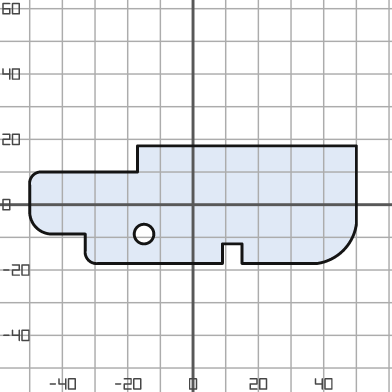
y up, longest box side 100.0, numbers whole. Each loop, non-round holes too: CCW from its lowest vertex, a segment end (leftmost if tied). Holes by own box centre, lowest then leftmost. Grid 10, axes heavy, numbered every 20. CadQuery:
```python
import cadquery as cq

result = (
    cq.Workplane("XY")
    .moveTo(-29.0, -18.0)
    .lineTo(9.0, -18.0)
    .lineTo(9.0, -12.0)
    .lineTo(15.0, -12.0)
    .lineTo(15.0, -18.0)
    .lineTo(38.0, -18.0)
    .threePointArc((46.0, -14.0), (50.0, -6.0))
    .lineTo(50.0, 18.0)
    .lineTo(-17.0, 18.0)
    .lineTo(-17.0, 10.0)
    .lineTo(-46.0, 10.0)
    .threePointArc((-49.0, 9.0), (-50.0, 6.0))
    .lineTo(-50.0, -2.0)
    .threePointArc((-48.0, -7.0), (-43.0, -9.0))
    .lineTo(-33.0, -9.0)
    .lineTo(-33.0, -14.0)
    .threePointArc((-32.0, -17.0), (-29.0, -18.0))
    .close()
    .moveTo(-15.0, -9.0)
    .circle(3.0)
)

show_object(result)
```